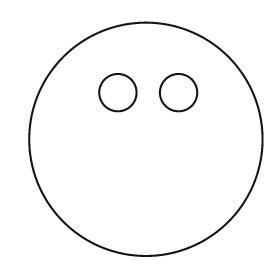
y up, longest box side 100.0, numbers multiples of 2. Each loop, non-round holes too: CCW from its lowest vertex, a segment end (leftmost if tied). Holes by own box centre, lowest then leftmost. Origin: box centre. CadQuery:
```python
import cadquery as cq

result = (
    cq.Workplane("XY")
    .moveTo(0.0, 0.0)
    .circle(50.0)
    .moveTo(-12.0, 20.0)
    .circle(8.0)
    .moveTo(14.0, 20.0)
    .circle(8.0)
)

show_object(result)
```